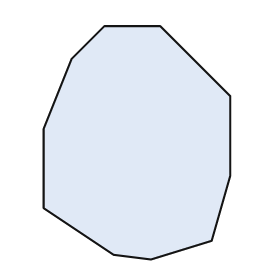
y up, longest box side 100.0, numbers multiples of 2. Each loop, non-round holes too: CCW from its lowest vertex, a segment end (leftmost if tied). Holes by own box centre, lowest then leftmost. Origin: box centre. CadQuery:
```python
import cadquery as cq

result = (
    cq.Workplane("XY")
    .moveTo(6.0, -50.0)
    .lineTo(32.0, -42.0)
    .lineTo(40.0, -14.0)
    .lineTo(40.0, 20.0)
    .lineTo(10.0, 50.0)
    .lineTo(-14.0, 50.0)
    .lineTo(-28.0, 36.0)
    .lineTo(-40.0, 6.0)
    .lineTo(-40.0, -28.0)
    .lineTo(-10.0, -48.0)
    .close()
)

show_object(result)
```